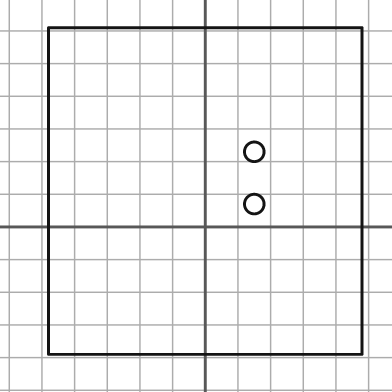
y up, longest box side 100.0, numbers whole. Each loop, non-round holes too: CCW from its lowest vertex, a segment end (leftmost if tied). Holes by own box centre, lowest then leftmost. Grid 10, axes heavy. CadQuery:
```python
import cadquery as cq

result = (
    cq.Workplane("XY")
    .moveTo(-48.0, -39.0)
    .lineTo(48.0, -39.0)
    .lineTo(48.0, 61.0)
    .lineTo(-48.0, 61.0)
    .close()
    .moveTo(15.0, 7.0)
    .circle(3.0)
    .moveTo(15.0, 23.0)
    .circle(3.0)
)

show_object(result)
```